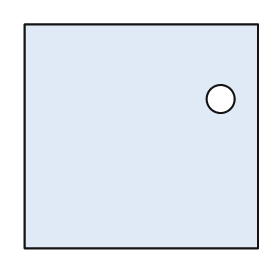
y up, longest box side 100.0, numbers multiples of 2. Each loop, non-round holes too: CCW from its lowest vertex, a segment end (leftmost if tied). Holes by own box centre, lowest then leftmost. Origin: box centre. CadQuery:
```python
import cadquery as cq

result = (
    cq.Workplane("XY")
    .moveTo(-50.0, -48.0)
    .lineTo(50.0, -48.0)
    .lineTo(50.0, 48.0)
    .lineTo(-50.0, 48.0)
    .close()
    .moveTo(34.0, 16.0)
    .circle(6.0)
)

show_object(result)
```